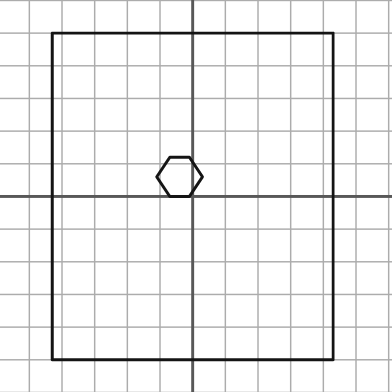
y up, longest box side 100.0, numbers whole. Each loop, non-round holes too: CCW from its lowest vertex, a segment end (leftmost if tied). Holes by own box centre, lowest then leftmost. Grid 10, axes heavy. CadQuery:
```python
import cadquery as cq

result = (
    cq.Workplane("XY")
    .moveTo(-43.0, -50.0)
    .lineTo(43.0, -50.0)
    .lineTo(43.0, 50.0)
    .lineTo(-43.0, 50.0)
    .close()
    .moveTo(-7.0, 0.0)
    .lineTo(-1.0, 0.0)
    .lineTo(3.0, 6.0)
    .lineTo(-1.0, 12.0)
    .lineTo(-7.0, 12.0)
    .lineTo(-11.0, 6.0)
    .close()
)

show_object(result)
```